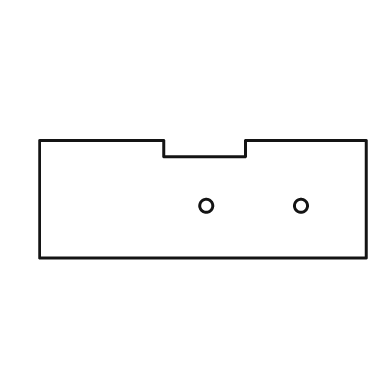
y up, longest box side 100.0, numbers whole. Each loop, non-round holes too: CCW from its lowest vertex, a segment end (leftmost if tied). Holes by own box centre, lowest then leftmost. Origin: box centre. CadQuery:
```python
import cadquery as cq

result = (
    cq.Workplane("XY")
    .moveTo(-50.0, -18.0)
    .lineTo(50.0, -18.0)
    .lineTo(50.0, 18.0)
    .lineTo(13.0, 18.0)
    .lineTo(13.0, 13.0)
    .lineTo(-12.0, 13.0)
    .lineTo(-12.0, 18.0)
    .lineTo(-50.0, 18.0)
    .close()
    .moveTo(1.0, -2.0)
    .circle(2.0)
    .moveTo(30.0, -2.0)
    .circle(2.0)
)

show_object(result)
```